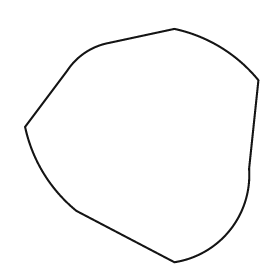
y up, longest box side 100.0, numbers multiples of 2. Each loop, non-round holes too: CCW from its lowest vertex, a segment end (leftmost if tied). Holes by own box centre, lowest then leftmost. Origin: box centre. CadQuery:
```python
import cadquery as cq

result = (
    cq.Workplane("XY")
    .moveTo(14.0, -50.0)
    .threePointArc((38.0, -36.0), (46.0, -10.0))
    .lineTo(50.0, 28.0)
    .threePointArc((34.0, 42.0), (14.0, 50.0))
    .lineTo(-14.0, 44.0)
    .threePointArc((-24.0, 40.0), (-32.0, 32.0))
    .lineTo(-50.0, 8.0)
    .threePointArc((-42.0, -12.0), (-28.0, -28.0))
    .close()
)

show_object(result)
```